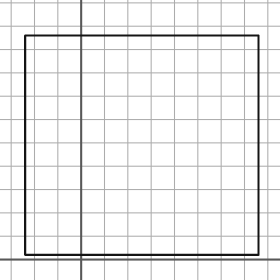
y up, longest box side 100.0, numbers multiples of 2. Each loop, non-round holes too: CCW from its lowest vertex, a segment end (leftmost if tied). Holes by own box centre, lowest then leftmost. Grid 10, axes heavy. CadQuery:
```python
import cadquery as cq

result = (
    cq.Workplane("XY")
    .moveTo(-24.0, 2.0)
    .lineTo(76.0, 2.0)
    .lineTo(76.0, 96.0)
    .lineTo(-24.0, 96.0)
    .close()
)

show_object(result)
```